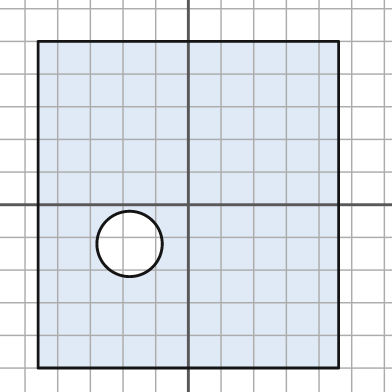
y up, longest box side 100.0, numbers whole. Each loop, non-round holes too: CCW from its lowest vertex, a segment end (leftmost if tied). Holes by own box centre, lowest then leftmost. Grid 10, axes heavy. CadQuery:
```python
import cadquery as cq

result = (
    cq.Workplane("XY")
    .moveTo(-46.0, -50.0)
    .lineTo(46.0, -50.0)
    .lineTo(46.0, 50.0)
    .lineTo(-46.0, 50.0)
    .close()
    .moveTo(-18.0, -12.0)
    .circle(10.0)
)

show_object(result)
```